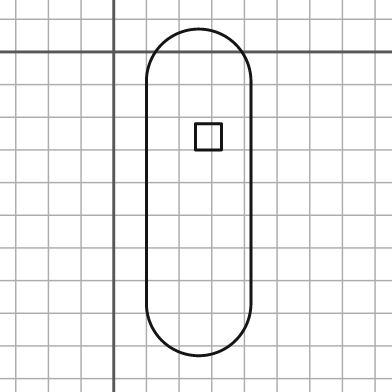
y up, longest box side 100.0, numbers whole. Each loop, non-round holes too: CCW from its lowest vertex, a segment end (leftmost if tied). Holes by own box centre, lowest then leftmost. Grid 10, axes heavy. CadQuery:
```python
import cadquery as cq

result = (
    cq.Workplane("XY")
    .moveTo(10.0, -77.0)
    .threePointArc((26.0, -93.0), (42.0, -77.0))
    .lineTo(42.0, -9.0)
    .threePointArc((26.0, 7.0), (10.0, -9.0))
    .close()
    .moveTo(25.0, -30.0)
    .lineTo(33.0, -30.0)
    .lineTo(33.0, -22.0)
    .lineTo(25.0, -22.0)
    .close()
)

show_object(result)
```